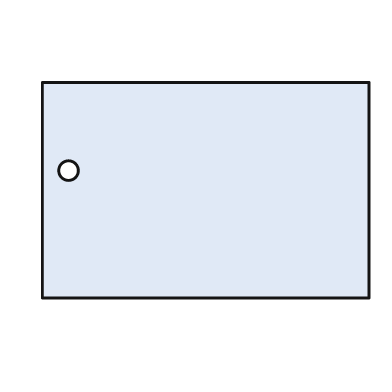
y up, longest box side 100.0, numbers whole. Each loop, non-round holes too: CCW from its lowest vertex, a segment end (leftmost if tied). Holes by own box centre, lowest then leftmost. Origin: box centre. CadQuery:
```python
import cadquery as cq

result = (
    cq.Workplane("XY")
    .moveTo(-50.0, -33.0)
    .lineTo(50.0, -33.0)
    .lineTo(50.0, 33.0)
    .lineTo(-50.0, 33.0)
    .close()
    .moveTo(-42.0, 6.0)
    .circle(3.0)
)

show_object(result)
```